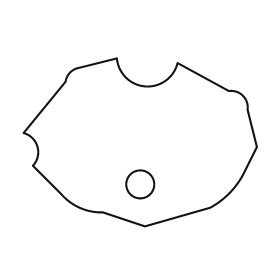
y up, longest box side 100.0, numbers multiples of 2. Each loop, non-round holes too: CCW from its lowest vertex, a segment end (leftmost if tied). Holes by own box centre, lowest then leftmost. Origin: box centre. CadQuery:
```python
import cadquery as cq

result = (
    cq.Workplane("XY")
    .moveTo(2.0, -36.0)
    .lineTo(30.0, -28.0)
    .threePointArc((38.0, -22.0), (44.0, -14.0))
    .lineTo(50.0, -2.0)
    .lineTo(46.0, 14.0)
    .threePointArc((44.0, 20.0), (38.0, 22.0))
    .lineTo(16.0, 34.0)
    .threePointArc((2.0, 24.0), (-10.0, 36.0))
    .lineTo(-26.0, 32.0)
    .threePointArc((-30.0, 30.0), (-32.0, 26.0))
    .lineTo(-50.0, 4.0)
    .threePointArc((-44.0, -2.0), (-46.0, -10.0))
    .lineTo(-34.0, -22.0)
    .threePointArc((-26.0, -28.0), (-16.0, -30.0))
    .close()
    .moveTo(0.0, -18.0)
    .circle(6.0)
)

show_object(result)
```